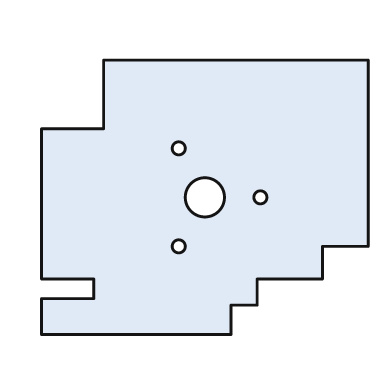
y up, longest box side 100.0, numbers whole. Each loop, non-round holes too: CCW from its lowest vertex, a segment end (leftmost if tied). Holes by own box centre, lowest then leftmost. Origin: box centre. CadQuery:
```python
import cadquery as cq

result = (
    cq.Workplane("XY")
    .moveTo(-50.0, -42.0)
    .lineTo(8.0, -42.0)
    .lineTo(8.0, -33.0)
    .lineTo(16.0, -33.0)
    .lineTo(16.0, -25.0)
    .lineTo(36.0, -25.0)
    .lineTo(36.0, -15.0)
    .lineTo(50.0, -15.0)
    .lineTo(50.0, 42.0)
    .lineTo(-31.0, 42.0)
    .lineTo(-31.0, 21.0)
    .lineTo(-50.0, 21.0)
    .lineTo(-50.0, -25.0)
    .lineTo(-34.0, -25.0)
    .lineTo(-34.0, -31.0)
    .lineTo(-50.0, -31.0)
    .close()
    .moveTo(-8.0, -15.0)
    .circle(2.0)
    .moveTo(0.0, 0.0)
    .circle(6.0)
    .moveTo(17.0, 0.0)
    .circle(2.0)
    .moveTo(-8.0, 15.0)
    .circle(2.0)
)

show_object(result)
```